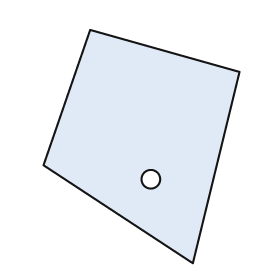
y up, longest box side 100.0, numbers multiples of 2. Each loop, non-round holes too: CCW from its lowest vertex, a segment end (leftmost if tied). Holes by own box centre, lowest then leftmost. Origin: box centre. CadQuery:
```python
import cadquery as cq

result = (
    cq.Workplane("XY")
    .moveTo(22.0, -50.0)
    .lineTo(42.0, 32.0)
    .lineTo(-22.0, 50.0)
    .lineTo(-42.0, -8.0)
    .close()
    .moveTo(4.0, -14.0)
    .circle(4.0)
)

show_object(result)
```